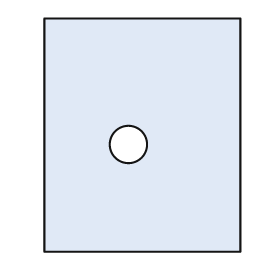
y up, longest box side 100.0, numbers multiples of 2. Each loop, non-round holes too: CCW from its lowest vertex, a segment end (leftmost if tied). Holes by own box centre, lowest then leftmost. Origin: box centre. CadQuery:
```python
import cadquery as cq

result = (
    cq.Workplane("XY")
    .moveTo(-42.0, -50.0)
    .lineTo(42.0, -50.0)
    .lineTo(42.0, 50.0)
    .lineTo(-42.0, 50.0)
    .close()
    .moveTo(-6.0, -4.0)
    .circle(8.0)
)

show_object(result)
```